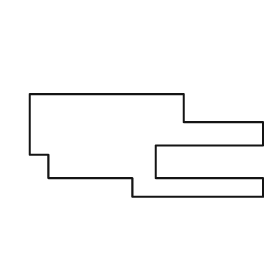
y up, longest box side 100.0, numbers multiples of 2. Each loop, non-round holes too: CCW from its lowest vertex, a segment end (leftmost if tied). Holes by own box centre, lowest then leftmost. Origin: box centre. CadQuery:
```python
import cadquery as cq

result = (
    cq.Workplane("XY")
    .moveTo(-6.0, -22.0)
    .lineTo(50.0, -22.0)
    .lineTo(50.0, -14.0)
    .lineTo(4.0, -14.0)
    .lineTo(4.0, 0.0)
    .lineTo(50.0, 0.0)
    .lineTo(50.0, 10.0)
    .lineTo(16.0, 10.0)
    .lineTo(16.0, 22.0)
    .lineTo(-50.0, 22.0)
    .lineTo(-50.0, -4.0)
    .lineTo(-42.0, -4.0)
    .lineTo(-42.0, -14.0)
    .lineTo(-6.0, -14.0)
    .close()
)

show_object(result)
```